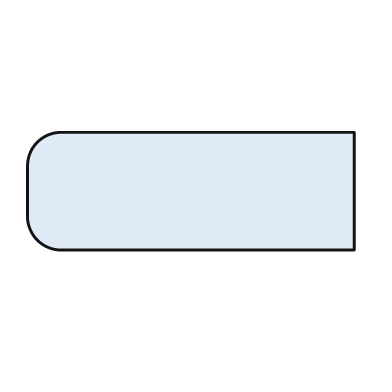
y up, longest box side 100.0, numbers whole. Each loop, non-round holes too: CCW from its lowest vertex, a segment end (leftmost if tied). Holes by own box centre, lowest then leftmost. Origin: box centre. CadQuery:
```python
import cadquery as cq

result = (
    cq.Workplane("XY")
    .moveTo(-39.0, -18.0)
    .lineTo(50.0, -18.0)
    .lineTo(50.0, 18.0)
    .lineTo(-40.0, 18.0)
    .threePointArc((-47.0, 15.0), (-50.0, 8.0))
    .lineTo(-50.0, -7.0)
    .threePointArc((-47.0, -15.0), (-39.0, -18.0))
    .close()
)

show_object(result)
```